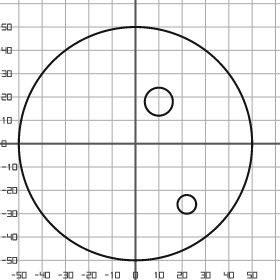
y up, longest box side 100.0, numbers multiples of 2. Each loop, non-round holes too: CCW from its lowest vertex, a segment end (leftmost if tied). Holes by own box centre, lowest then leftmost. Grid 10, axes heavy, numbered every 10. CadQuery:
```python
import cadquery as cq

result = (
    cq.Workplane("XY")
    .moveTo(0.0, 0.0)
    .circle(50.0)
    .moveTo(22.0, -26.0)
    .circle(4.0)
    .moveTo(10.0, 18.0)
    .circle(6.0)
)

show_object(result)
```